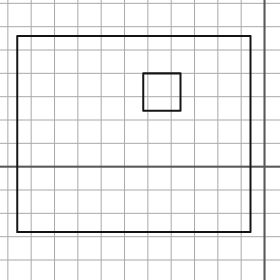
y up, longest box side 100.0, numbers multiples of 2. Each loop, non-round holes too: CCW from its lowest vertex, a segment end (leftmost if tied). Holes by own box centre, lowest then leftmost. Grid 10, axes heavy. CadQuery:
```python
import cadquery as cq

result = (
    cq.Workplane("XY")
    .moveTo(-106.0, -28.0)
    .lineTo(-6.0, -28.0)
    .lineTo(-6.0, 56.0)
    .lineTo(-106.0, 56.0)
    .close()
    .moveTo(-52.0, 24.0)
    .lineTo(-36.0, 24.0)
    .lineTo(-36.0, 40.0)
    .lineTo(-52.0, 40.0)
    .close()
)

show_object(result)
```